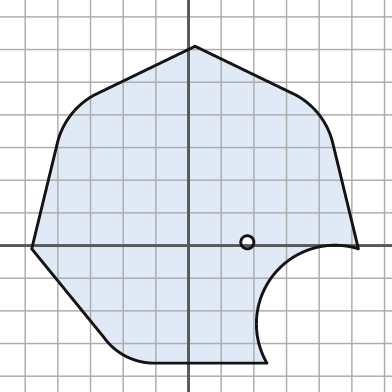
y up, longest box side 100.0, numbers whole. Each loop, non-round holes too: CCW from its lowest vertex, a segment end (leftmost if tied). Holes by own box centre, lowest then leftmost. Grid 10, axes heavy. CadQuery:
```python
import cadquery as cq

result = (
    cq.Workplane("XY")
    .moveTo(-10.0, -36.0)
    .lineTo(24.0, -36.0)
    .threePointArc((26.0, -9.0), (52.0, -1.0))
    .lineTo(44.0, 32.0)
    .threePointArc((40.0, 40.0), (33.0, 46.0))
    .lineTo(2.0, 61.0)
    .lineTo(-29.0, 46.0)
    .threePointArc((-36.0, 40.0), (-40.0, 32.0))
    .lineTo(-48.0, -1.0)
    .lineTo(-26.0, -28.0)
    .threePointArc((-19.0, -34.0), (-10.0, -36.0))
    .close()
    .moveTo(18.0, 1.0)
    .circle(2.0)
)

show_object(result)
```